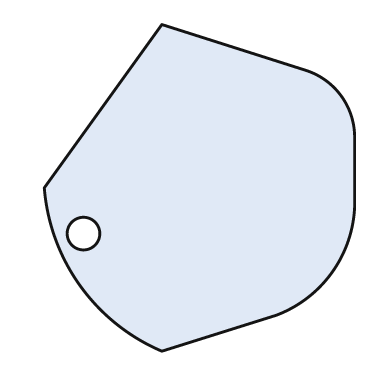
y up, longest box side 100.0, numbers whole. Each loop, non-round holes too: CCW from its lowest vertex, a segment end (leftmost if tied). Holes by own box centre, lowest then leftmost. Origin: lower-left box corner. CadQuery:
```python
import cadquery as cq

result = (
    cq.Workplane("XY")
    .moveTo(36.0, 0.0)
    .lineTo(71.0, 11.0)
    .threePointArc((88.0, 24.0), (95.0, 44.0))
    .lineTo(95.0, 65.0)
    .threePointArc((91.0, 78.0), (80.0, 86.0))
    .lineTo(36.0, 100.0)
    .lineTo(0.0, 50.0)
    .threePointArc((11.0, 20.0), (36.0, 0.0))
    .close()
    .moveTo(12.0, 36.0)
    .circle(5.0)
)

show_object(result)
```